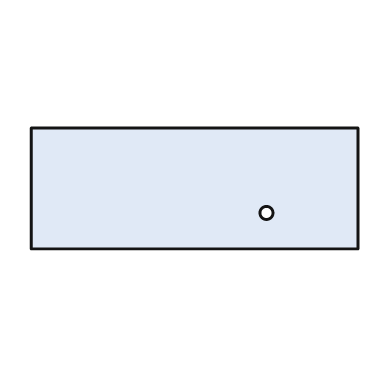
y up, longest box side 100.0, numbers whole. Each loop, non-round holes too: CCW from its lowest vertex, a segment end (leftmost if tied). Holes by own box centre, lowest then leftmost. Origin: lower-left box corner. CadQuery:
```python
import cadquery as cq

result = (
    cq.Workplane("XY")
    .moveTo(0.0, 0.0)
    .lineTo(100.0, 0.0)
    .lineTo(100.0, 37.0)
    .lineTo(0.0, 37.0)
    .close()
    .moveTo(72.0, 11.0)
    .circle(2.0)
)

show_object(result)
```